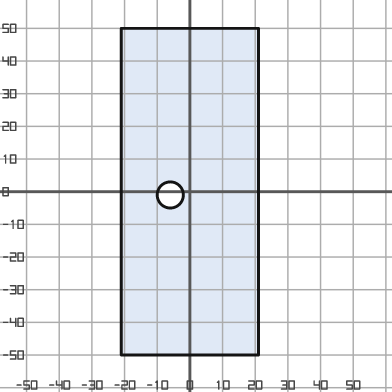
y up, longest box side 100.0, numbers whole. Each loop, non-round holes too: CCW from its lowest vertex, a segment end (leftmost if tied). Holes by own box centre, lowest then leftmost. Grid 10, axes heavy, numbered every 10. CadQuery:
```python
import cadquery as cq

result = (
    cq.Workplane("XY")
    .moveTo(-21.0, -50.0)
    .lineTo(21.0, -50.0)
    .lineTo(21.0, 50.0)
    .lineTo(-21.0, 50.0)
    .close()
    .moveTo(-6.0, -1.0)
    .circle(4.0)
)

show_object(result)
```